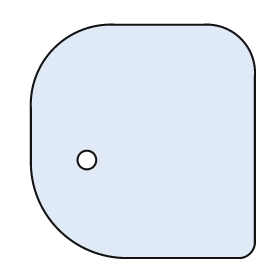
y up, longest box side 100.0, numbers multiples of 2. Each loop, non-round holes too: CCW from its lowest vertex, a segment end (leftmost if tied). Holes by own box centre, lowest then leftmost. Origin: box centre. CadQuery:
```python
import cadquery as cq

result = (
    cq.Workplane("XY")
    .moveTo(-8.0, -50.0)
    .lineTo(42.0, -50.0)
    .threePointArc((46.0, -48.0), (48.0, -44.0))
    .lineTo(48.0, 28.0)
    .threePointArc((42.0, 44.0), (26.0, 50.0))
    .lineTo(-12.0, 50.0)
    .threePointArc((-38.0, 40.0), (-48.0, 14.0))
    .lineTo(-48.0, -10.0)
    .threePointArc((-36.0, -38.0), (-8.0, -50.0))
    .close()
    .moveTo(-24.0, -8.0)
    .circle(4.0)
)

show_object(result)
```